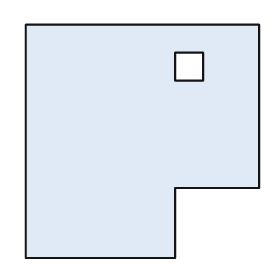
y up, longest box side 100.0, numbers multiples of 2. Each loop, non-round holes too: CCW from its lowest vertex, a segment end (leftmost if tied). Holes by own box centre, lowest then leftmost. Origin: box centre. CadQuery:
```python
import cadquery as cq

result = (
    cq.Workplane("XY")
    .moveTo(-50.0, -50.0)
    .lineTo(14.0, -50.0)
    .lineTo(14.0, -20.0)
    .lineTo(50.0, -20.0)
    .lineTo(50.0, 50.0)
    .lineTo(-50.0, 50.0)
    .close()
    .moveTo(14.0, 26.0)
    .lineTo(26.0, 26.0)
    .lineTo(26.0, 38.0)
    .lineTo(14.0, 38.0)
    .close()
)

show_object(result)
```